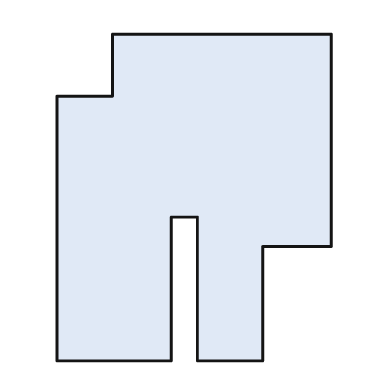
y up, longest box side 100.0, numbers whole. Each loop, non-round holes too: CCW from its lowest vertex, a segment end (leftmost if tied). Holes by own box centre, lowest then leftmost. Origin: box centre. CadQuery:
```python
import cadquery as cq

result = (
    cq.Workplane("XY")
    .moveTo(-42.0, -50.0)
    .lineTo(-7.0, -50.0)
    .lineTo(-7.0, -6.0)
    .lineTo(1.0, -6.0)
    .lineTo(1.0, -50.0)
    .lineTo(21.0, -50.0)
    .lineTo(21.0, -15.0)
    .lineTo(42.0, -15.0)
    .lineTo(42.0, 50.0)
    .lineTo(-25.0, 50.0)
    .lineTo(-25.0, 31.0)
    .lineTo(-42.0, 31.0)
    .close()
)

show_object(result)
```